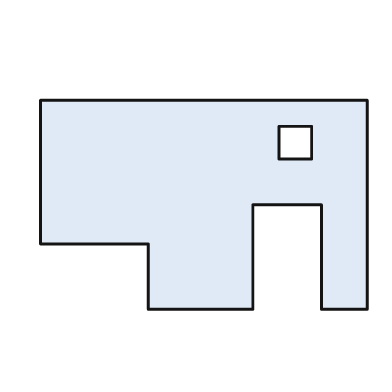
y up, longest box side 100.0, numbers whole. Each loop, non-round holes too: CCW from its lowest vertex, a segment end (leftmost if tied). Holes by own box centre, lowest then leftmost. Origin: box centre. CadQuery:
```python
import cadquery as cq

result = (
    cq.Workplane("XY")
    .moveTo(-17.0, -32.0)
    .lineTo(15.0, -32.0)
    .lineTo(15.0, 0.0)
    .lineTo(36.0, 0.0)
    .lineTo(36.0, -32.0)
    .lineTo(50.0, -32.0)
    .lineTo(50.0, 32.0)
    .lineTo(-50.0, 32.0)
    .lineTo(-50.0, -12.0)
    .lineTo(-17.0, -12.0)
    .close()
    .moveTo(23.0, 14.0)
    .lineTo(33.0, 14.0)
    .lineTo(33.0, 24.0)
    .lineTo(23.0, 24.0)
    .close()
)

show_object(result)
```